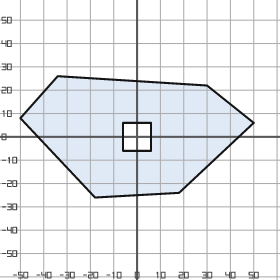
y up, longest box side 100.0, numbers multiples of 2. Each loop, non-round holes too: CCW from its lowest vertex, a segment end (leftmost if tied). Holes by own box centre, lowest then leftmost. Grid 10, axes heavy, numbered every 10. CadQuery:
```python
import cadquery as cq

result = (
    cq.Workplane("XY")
    .moveTo(-18.0, -26.0)
    .lineTo(18.0, -24.0)
    .lineTo(50.0, 6.0)
    .lineTo(30.0, 22.0)
    .lineTo(-34.0, 26.0)
    .lineTo(-50.0, 8.0)
    .close()
    .moveTo(-6.0, -6.0)
    .lineTo(6.0, -6.0)
    .lineTo(6.0, 6.0)
    .lineTo(-6.0, 6.0)
    .close()
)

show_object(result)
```